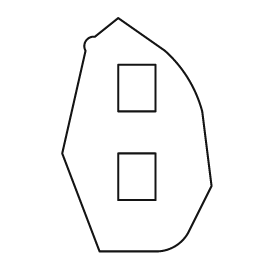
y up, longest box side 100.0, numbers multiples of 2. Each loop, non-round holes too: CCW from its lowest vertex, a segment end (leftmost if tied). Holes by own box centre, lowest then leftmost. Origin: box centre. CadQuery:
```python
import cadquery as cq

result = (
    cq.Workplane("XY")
    .moveTo(-16.0, -50.0)
    .lineTo(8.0, -50.0)
    .threePointArc((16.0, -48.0), (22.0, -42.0))
    .lineTo(32.0, -22.0)
    .lineTo(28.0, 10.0)
    .threePointArc((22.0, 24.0), (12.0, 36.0))
    .lineTo(-8.0, 50.0)
    .lineTo(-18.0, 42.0)
    .threePointArc((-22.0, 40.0), (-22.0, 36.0))
    .lineTo(-32.0, -8.0)
    .close()
    .moveTo(-8.0, -28.0)
    .lineTo(8.0, -28.0)
    .lineTo(8.0, -8.0)
    .lineTo(-8.0, -8.0)
    .close()
    .moveTo(-8.0, 10.0)
    .lineTo(8.0, 10.0)
    .lineTo(8.0, 30.0)
    .lineTo(-8.0, 30.0)
    .close()
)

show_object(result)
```